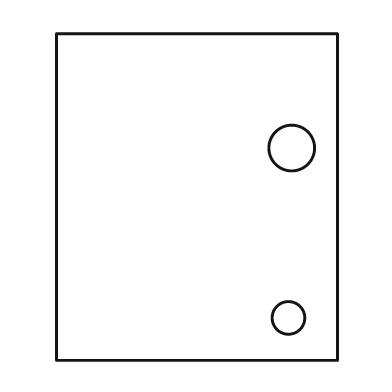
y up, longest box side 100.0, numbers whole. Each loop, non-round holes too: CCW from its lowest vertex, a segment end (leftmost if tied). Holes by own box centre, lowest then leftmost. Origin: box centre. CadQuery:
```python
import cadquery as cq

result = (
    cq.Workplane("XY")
    .moveTo(-43.0, -50.0)
    .lineTo(43.0, -50.0)
    .lineTo(43.0, 50.0)
    .lineTo(-43.0, 50.0)
    .close()
    .moveTo(28.0, -37.0)
    .circle(5.0)
    .moveTo(29.0, 15.0)
    .circle(7.0)
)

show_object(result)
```